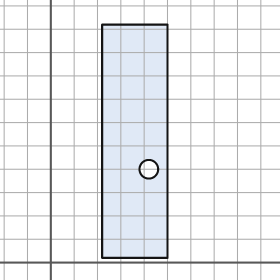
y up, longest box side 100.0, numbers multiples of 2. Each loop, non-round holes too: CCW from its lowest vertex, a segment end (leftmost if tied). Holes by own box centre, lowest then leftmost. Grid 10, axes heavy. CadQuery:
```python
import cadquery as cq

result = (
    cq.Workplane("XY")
    .moveTo(22.0, 2.0)
    .lineTo(50.0, 2.0)
    .lineTo(50.0, 102.0)
    .lineTo(22.0, 102.0)
    .close()
    .moveTo(42.0, 40.0)
    .circle(4.0)
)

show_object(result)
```